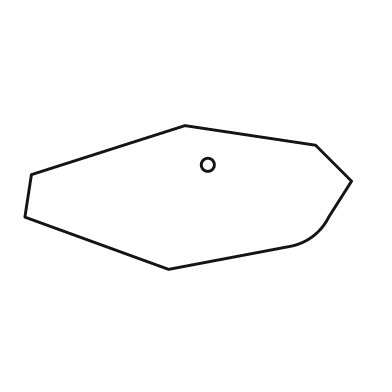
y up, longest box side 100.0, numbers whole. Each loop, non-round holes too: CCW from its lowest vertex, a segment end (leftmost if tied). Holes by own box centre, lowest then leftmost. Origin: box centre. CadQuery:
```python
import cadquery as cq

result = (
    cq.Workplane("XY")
    .moveTo(-6.0, -22.0)
    .lineTo(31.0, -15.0)
    .threePointArc((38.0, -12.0), (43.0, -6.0))
    .lineTo(50.0, 5.0)
    .lineTo(39.0, 16.0)
    .lineTo(-1.0, 22.0)
    .lineTo(-48.0, 7.0)
    .lineTo(-50.0, -6.0)
    .close()
    .moveTo(6.0, 10.0)
    .circle(2.0)
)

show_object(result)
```